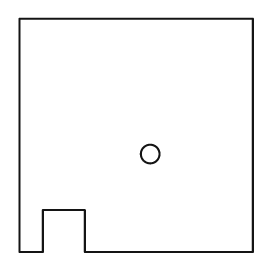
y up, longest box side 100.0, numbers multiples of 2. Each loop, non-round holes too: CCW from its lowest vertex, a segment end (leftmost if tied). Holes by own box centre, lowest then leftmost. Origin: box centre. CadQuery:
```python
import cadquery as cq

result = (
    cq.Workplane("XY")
    .moveTo(-50.0, -50.0)
    .lineTo(-40.0, -50.0)
    .lineTo(-40.0, -32.0)
    .lineTo(-22.0, -32.0)
    .lineTo(-22.0, -50.0)
    .lineTo(50.0, -50.0)
    .lineTo(50.0, 50.0)
    .lineTo(-50.0, 50.0)
    .close()
    .moveTo(6.0, -8.0)
    .circle(4.0)
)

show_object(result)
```